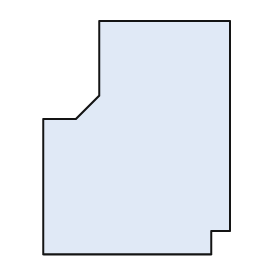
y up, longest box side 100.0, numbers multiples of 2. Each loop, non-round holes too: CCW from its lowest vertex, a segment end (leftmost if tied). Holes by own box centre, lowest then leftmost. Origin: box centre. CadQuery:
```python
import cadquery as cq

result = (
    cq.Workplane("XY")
    .moveTo(-40.0, -50.0)
    .lineTo(32.0, -50.0)
    .lineTo(32.0, -40.0)
    .lineTo(40.0, -40.0)
    .lineTo(40.0, 50.0)
    .lineTo(-16.0, 50.0)
    .lineTo(-16.0, 18.0)
    .lineTo(-26.0, 8.0)
    .lineTo(-40.0, 8.0)
    .close()
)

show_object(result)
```